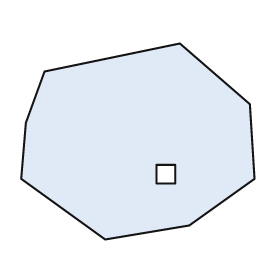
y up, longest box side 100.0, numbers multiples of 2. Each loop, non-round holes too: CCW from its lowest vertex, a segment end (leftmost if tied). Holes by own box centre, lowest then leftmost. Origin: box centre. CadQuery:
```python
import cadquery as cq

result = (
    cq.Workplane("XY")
    .moveTo(-14.0, -42.0)
    .lineTo(22.0, -36.0)
    .lineTo(50.0, -16.0)
    .lineTo(48.0, 16.0)
    .lineTo(18.0, 42.0)
    .lineTo(-40.0, 30.0)
    .lineTo(-48.0, 8.0)
    .lineTo(-50.0, -16.0)
    .close()
    .moveTo(8.0, -18.0)
    .lineTo(16.0, -18.0)
    .lineTo(16.0, -10.0)
    .lineTo(8.0, -10.0)
    .close()
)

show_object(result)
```